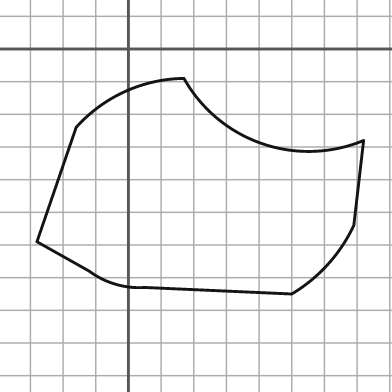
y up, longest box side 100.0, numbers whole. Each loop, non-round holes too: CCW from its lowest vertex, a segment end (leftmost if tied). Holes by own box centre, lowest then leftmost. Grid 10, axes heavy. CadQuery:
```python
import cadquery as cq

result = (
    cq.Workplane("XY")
    .moveTo(50.0, -75.0)
    .threePointArc((61.0, -66.0), (69.0, -54.0))
    .lineTo(72.0, -28.0)
    .threePointArc((41.0, -29.0), (17.0, -9.0))
    .threePointArc((-1.0, -13.0), (-16.0, -24.0))
    .lineTo(-28.0, -59.0)
    .lineTo(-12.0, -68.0)
    .threePointArc((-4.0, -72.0), (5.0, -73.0))
    .close()
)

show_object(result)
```